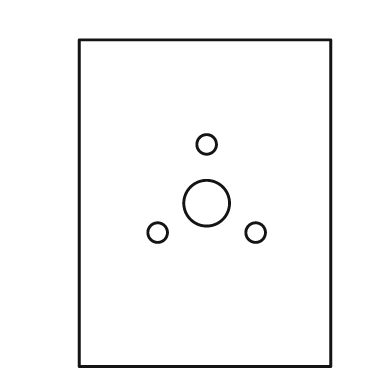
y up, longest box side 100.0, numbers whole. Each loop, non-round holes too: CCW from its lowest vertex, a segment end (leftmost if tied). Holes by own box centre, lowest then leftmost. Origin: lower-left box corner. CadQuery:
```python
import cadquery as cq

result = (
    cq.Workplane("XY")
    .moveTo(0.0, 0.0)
    .lineTo(77.0, 0.0)
    .lineTo(77.0, 100.0)
    .lineTo(0.0, 100.0)
    .close()
    .moveTo(24.0, 41.0)
    .circle(3.0)
    .moveTo(54.0, 41.0)
    .circle(3.0)
    .moveTo(39.0, 50.0)
    .circle(7.0)
    .moveTo(39.0, 68.0)
    .circle(3.0)
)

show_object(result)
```